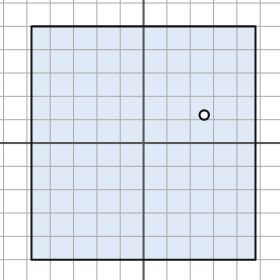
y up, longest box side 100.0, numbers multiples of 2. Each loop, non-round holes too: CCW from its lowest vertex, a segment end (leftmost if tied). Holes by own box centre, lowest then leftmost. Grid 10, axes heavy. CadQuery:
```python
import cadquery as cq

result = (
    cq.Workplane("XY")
    .moveTo(-48.0, -50.0)
    .lineTo(48.0, -50.0)
    .lineTo(48.0, 50.0)
    .lineTo(-48.0, 50.0)
    .close()
    .moveTo(26.0, 12.0)
    .circle(2.0)
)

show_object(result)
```